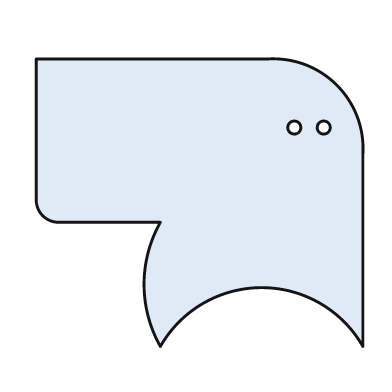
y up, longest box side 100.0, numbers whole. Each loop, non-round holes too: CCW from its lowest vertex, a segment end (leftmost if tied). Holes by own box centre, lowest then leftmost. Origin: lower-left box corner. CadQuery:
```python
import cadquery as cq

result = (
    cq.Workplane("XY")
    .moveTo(38.0, 0.0)
    .threePointArc((69.0, 18.0), (100.0, 0.0))
    .lineTo(100.0, 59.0)
    .threePointArc((92.0, 80.0), (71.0, 88.0))
    .lineTo(0.0, 88.0)
    .lineTo(0.0, 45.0)
    .threePointArc((2.0, 40.0), (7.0, 38.0))
    .lineTo(38.0, 38.0)
    .threePointArc((33.0, 19.0), (38.0, 0.0))
    .close()
    .moveTo(79.0, 67.0)
    .circle(2.0)
    .moveTo(88.0, 67.0)
    .circle(2.0)
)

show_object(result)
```